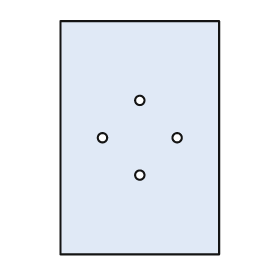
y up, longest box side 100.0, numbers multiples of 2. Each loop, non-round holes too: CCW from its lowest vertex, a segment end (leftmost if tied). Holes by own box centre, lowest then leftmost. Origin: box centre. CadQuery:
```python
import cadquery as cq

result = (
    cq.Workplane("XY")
    .moveTo(-34.0, -50.0)
    .lineTo(34.0, -50.0)
    .lineTo(34.0, 50.0)
    .lineTo(-34.0, 50.0)
    .close()
    .moveTo(0.0, -16.0)
    .circle(2.0)
    .moveTo(-16.0, 0.0)
    .circle(2.0)
    .moveTo(16.0, 0.0)
    .circle(2.0)
    .moveTo(0.0, 16.0)
    .circle(2.0)
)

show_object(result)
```